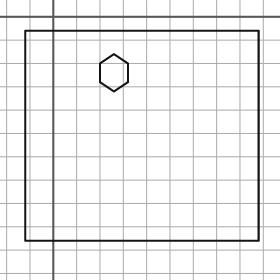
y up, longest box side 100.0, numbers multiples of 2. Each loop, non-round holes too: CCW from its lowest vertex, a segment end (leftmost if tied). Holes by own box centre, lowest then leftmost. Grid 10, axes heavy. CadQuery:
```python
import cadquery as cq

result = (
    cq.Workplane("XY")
    .moveTo(-12.0, -96.0)
    .lineTo(88.0, -96.0)
    .lineTo(88.0, -6.0)
    .lineTo(-12.0, -6.0)
    .close()
    .moveTo(26.0, -32.0)
    .lineTo(32.0, -28.0)
    .lineTo(32.0, -20.0)
    .lineTo(26.0, -16.0)
    .lineTo(20.0, -20.0)
    .lineTo(20.0, -28.0)
    .close()
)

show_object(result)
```